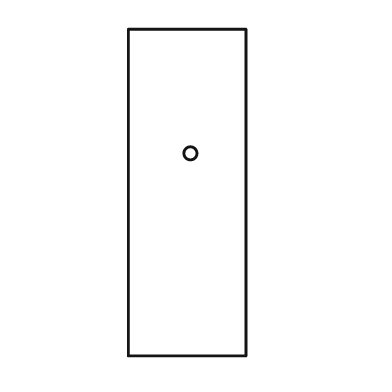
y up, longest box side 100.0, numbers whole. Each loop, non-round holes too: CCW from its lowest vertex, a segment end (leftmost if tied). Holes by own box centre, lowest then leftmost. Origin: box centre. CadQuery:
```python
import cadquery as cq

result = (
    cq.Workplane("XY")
    .moveTo(-18.0, -50.0)
    .lineTo(18.0, -50.0)
    .lineTo(18.0, 50.0)
    .lineTo(-18.0, 50.0)
    .close()
    .moveTo(1.0, 12.0)
    .circle(2.0)
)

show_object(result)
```